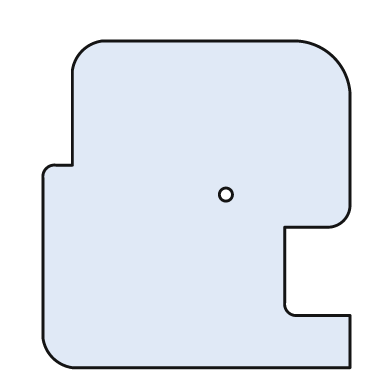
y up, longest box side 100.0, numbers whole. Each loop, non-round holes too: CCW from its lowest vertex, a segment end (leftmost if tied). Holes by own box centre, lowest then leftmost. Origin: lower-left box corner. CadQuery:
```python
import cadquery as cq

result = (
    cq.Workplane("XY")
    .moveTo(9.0, 0.0)
    .lineTo(94.0, 0.0)
    .lineTo(94.0, 16.0)
    .lineTo(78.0, 16.0)
    .threePointArc((75.0, 17.0), (74.0, 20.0))
    .lineTo(74.0, 43.0)
    .lineTo(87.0, 43.0)
    .threePointArc((92.0, 45.0), (94.0, 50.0))
    .lineTo(94.0, 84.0)
    .threePointArc((89.0, 95.0), (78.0, 100.0))
    .lineTo(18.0, 100.0)
    .threePointArc((12.0, 97.0), (9.0, 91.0))
    .lineTo(9.0, 62.0)
    .lineTo(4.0, 62.0)
    .threePointArc((1.0, 61.0), (0.0, 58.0))
    .lineTo(0.0, 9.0)
    .threePointArc((3.0, 3.0), (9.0, 0.0))
    .close()
    .moveTo(56.0, 53.0)
    .circle(2.0)
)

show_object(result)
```